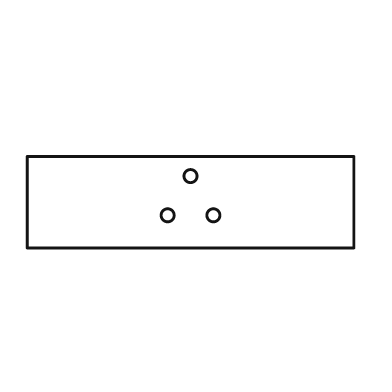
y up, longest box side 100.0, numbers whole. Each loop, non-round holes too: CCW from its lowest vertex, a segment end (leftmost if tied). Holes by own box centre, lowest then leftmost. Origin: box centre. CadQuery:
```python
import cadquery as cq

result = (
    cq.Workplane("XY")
    .moveTo(-50.0, -14.0)
    .lineTo(50.0, -14.0)
    .lineTo(50.0, 14.0)
    .lineTo(-50.0, 14.0)
    .close()
    .moveTo(-7.0, -4.0)
    .circle(2.0)
    .moveTo(7.0, -4.0)
    .circle(2.0)
    .moveTo(0.0, 8.0)
    .circle(2.0)
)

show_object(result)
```